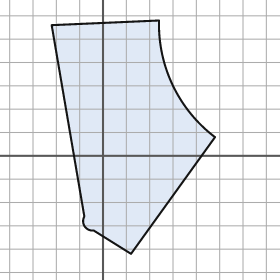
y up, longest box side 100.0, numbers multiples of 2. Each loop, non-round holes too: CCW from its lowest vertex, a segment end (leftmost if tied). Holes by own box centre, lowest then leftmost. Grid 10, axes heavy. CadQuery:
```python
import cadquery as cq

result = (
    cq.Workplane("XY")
    .moveTo(12.0, -42.0)
    .lineTo(48.0, 8.0)
    .threePointArc((30.0, 30.0), (24.0, 58.0))
    .lineTo(-22.0, 56.0)
    .lineTo(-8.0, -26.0)
    .threePointArc((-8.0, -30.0), (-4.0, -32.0))
    .close()
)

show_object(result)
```